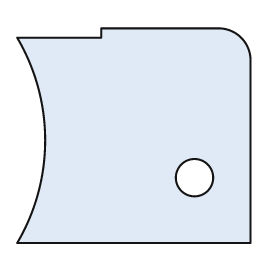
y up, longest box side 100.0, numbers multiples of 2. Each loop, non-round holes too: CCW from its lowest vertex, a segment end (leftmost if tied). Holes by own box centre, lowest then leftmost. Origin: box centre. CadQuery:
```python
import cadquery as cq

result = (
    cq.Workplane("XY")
    .moveTo(-50.0, -46.0)
    .lineTo(50.0, -46.0)
    .lineTo(50.0, 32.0)
    .threePointArc((46.0, 42.0), (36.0, 46.0))
    .lineTo(-14.0, 46.0)
    .lineTo(-14.0, 42.0)
    .lineTo(-50.0, 42.0)
    .threePointArc((-38.0, -2.0), (-50.0, -46.0))
    .close()
    .moveTo(26.0, -18.0)
    .circle(8.0)
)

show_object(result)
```